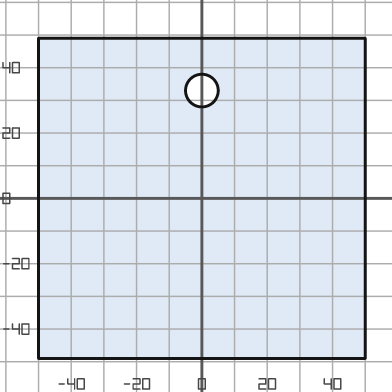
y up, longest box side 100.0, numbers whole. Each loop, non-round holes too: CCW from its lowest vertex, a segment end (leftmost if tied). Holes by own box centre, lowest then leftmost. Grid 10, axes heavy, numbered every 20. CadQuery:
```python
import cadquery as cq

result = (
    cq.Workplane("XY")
    .moveTo(-50.0, -49.0)
    .lineTo(50.0, -49.0)
    .lineTo(50.0, 49.0)
    .lineTo(-50.0, 49.0)
    .close()
    .moveTo(0.0, 33.0)
    .circle(5.0)
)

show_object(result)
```